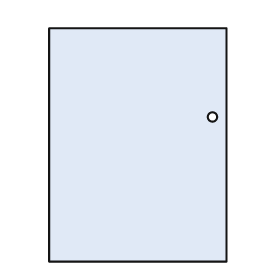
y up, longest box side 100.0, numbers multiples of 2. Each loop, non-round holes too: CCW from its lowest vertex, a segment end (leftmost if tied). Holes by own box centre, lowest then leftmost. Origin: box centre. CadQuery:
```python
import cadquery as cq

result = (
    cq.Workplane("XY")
    .moveTo(-38.0, -50.0)
    .lineTo(38.0, -50.0)
    .lineTo(38.0, 50.0)
    .lineTo(-38.0, 50.0)
    .close()
    .moveTo(32.0, 12.0)
    .circle(2.0)
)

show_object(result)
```